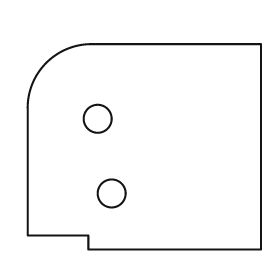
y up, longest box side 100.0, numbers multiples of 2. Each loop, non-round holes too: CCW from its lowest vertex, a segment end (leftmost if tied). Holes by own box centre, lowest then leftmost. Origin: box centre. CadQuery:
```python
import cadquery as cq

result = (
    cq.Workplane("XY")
    .moveTo(-24.0, -44.0)
    .lineTo(50.0, -44.0)
    .lineTo(50.0, 44.0)
    .lineTo(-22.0, 44.0)
    .threePointArc((-42.0, 36.0), (-50.0, 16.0))
    .lineTo(-50.0, -38.0)
    .lineTo(-24.0, -38.0)
    .close()
    .moveTo(-14.0, -20.0)
    .circle(6.0)
    .moveTo(-20.0, 12.0)
    .circle(6.0)
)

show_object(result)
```